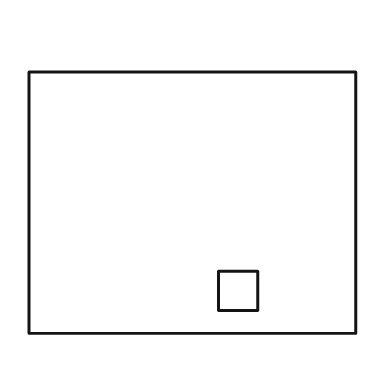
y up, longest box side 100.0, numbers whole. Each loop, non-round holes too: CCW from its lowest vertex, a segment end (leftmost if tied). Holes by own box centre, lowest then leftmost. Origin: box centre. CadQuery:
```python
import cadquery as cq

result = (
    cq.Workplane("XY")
    .moveTo(-50.0, -40.0)
    .lineTo(50.0, -40.0)
    .lineTo(50.0, 40.0)
    .lineTo(-50.0, 40.0)
    .close()
    .moveTo(8.0, -33.0)
    .lineTo(20.0, -33.0)
    .lineTo(20.0, -21.0)
    .lineTo(8.0, -21.0)
    .close()
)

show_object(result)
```